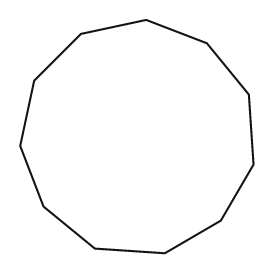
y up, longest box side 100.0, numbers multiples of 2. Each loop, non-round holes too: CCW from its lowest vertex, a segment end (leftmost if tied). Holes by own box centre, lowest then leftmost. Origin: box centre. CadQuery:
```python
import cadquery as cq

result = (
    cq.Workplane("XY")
    .moveTo(12.0, -50.0)
    .lineTo(36.0, -36.0)
    .lineTo(50.0, -12.0)
    .lineTo(48.0, 18.0)
    .lineTo(30.0, 40.0)
    .lineTo(4.0, 50.0)
    .lineTo(-24.0, 44.0)
    .lineTo(-44.0, 24.0)
    .lineTo(-50.0, -4.0)
    .lineTo(-40.0, -30.0)
    .lineTo(-18.0, -48.0)
    .close()
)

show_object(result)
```